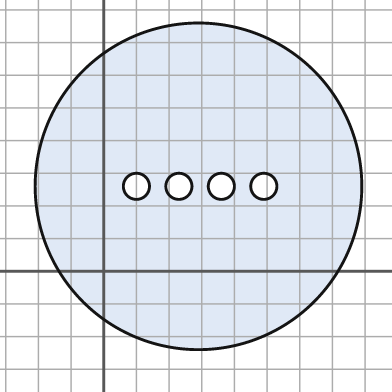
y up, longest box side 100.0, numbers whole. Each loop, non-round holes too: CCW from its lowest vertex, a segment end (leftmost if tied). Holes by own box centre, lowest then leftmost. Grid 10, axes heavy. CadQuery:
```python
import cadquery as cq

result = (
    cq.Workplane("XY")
    .moveTo(29.0, 26.0)
    .circle(50.0)
    .moveTo(10.0, 26.0)
    .circle(4.0)
    .moveTo(23.0, 26.0)
    .circle(4.0)
    .moveTo(36.0, 26.0)
    .circle(4.0)
    .moveTo(49.0, 26.0)
    .circle(4.0)
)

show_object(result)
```